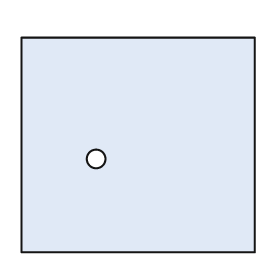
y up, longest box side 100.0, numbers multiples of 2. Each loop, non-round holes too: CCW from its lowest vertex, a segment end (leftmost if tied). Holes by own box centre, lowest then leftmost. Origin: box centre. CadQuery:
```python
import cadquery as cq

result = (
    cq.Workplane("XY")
    .moveTo(-50.0, -46.0)
    .lineTo(50.0, -46.0)
    .lineTo(50.0, 46.0)
    .lineTo(-50.0, 46.0)
    .close()
    .moveTo(-18.0, -6.0)
    .circle(4.0)
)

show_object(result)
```